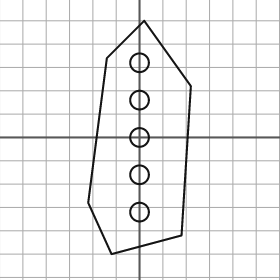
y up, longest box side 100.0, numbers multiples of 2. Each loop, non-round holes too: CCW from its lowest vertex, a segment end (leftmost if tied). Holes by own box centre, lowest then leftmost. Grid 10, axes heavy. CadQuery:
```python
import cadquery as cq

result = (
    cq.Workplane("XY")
    .moveTo(-12.0, -50.0)
    .lineTo(18.0, -42.0)
    .lineTo(22.0, 22.0)
    .lineTo(2.0, 50.0)
    .lineTo(-14.0, 34.0)
    .lineTo(-22.0, -28.0)
    .close()
    .moveTo(0.0, -32.0)
    .circle(4.0)
    .moveTo(0.0, -16.0)
    .circle(4.0)
    .moveTo(0.0, 0.0)
    .circle(4.0)
    .moveTo(0.0, 16.0)
    .circle(4.0)
    .moveTo(0.0, 32.0)
    .circle(4.0)
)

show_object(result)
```